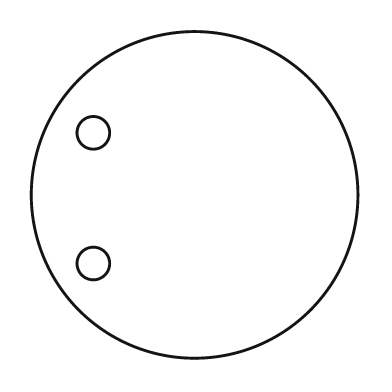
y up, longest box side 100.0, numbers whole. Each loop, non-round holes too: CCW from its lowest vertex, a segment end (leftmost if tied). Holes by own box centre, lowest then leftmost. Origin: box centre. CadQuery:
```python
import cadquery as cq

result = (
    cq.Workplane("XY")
    .moveTo(0.0, 0.0)
    .circle(50.0)
    .moveTo(-31.0, -21.0)
    .circle(5.0)
    .moveTo(-31.0, 19.0)
    .circle(5.0)
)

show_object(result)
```